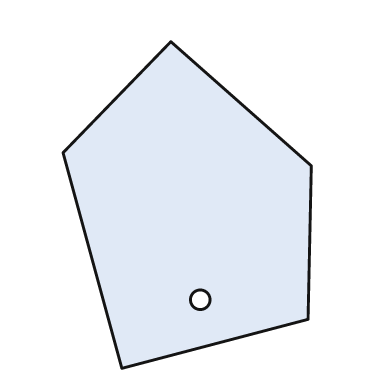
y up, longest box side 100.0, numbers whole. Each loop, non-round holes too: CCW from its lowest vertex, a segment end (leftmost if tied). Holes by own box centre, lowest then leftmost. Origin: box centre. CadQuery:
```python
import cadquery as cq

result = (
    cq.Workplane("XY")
    .moveTo(-20.0, -50.0)
    .lineTo(37.0, -35.0)
    .lineTo(38.0, 12.0)
    .lineTo(-5.0, 50.0)
    .lineTo(-38.0, 16.0)
    .close()
    .moveTo(4.0, -29.0)
    .circle(3.0)
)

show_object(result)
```